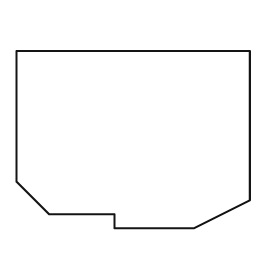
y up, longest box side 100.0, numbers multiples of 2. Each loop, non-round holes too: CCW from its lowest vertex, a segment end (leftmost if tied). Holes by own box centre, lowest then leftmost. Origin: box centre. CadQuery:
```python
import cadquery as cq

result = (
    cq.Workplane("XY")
    .moveTo(-8.0, -38.0)
    .lineTo(26.0, -38.0)
    .lineTo(50.0, -26.0)
    .lineTo(50.0, 38.0)
    .lineTo(-50.0, 38.0)
    .lineTo(-50.0, -18.0)
    .lineTo(-36.0, -32.0)
    .lineTo(-8.0, -32.0)
    .close()
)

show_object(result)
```